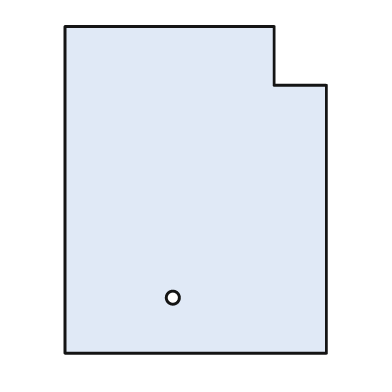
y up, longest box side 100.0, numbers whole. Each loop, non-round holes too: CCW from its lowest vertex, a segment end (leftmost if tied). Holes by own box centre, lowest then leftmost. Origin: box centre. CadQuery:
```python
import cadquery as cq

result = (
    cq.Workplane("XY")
    .moveTo(-40.0, -50.0)
    .lineTo(40.0, -50.0)
    .lineTo(40.0, 32.0)
    .lineTo(24.0, 32.0)
    .lineTo(24.0, 50.0)
    .lineTo(-40.0, 50.0)
    .close()
    .moveTo(-7.0, -33.0)
    .circle(2.0)
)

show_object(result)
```